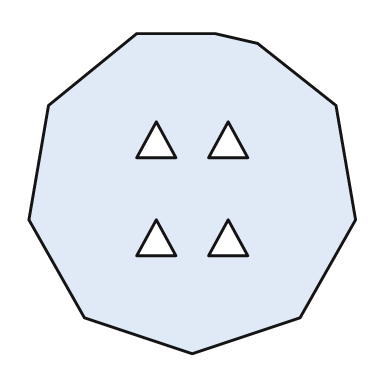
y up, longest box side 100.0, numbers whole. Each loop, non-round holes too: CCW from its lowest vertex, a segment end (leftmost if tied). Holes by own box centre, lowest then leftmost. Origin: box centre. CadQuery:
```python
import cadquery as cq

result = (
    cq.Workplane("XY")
    .moveTo(0.0, -49.0)
    .lineTo(33.0, -38.0)
    .lineTo(50.0, -8.0)
    .lineTo(44.0, 27.0)
    .lineTo(20.0, 46.0)
    .lineTo(7.0, 49.0)
    .lineTo(-17.0, 49.0)
    .lineTo(-44.0, 27.0)
    .lineTo(-50.0, -8.0)
    .lineTo(-33.0, -38.0)
    .close()
    .moveTo(-17.0, -19.0)
    .lineTo(-5.0, -19.0)
    .lineTo(-11.0, -8.0)
    .close()
    .moveTo(5.0, -19.0)
    .lineTo(17.0, -19.0)
    .lineTo(11.0, -8.0)
    .close()
    .moveTo(-17.0, 11.0)
    .lineTo(-5.0, 11.0)
    .lineTo(-11.0, 22.0)
    .close()
    .moveTo(5.0, 11.0)
    .lineTo(17.0, 11.0)
    .lineTo(11.0, 22.0)
    .close()
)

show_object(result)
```